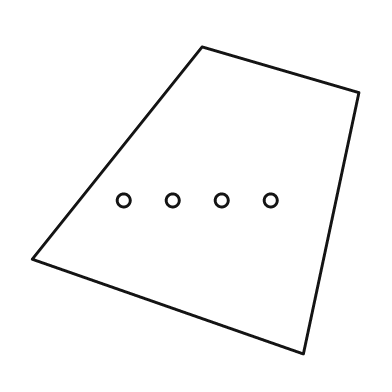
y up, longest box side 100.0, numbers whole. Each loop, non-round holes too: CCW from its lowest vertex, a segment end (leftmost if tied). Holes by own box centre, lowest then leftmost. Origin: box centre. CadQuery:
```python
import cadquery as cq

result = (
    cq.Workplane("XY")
    .moveTo(33.0, -47.0)
    .lineTo(50.0, 33.0)
    .lineTo(2.0, 47.0)
    .lineTo(-50.0, -18.0)
    .close()
    .moveTo(-22.0, 0.0)
    .circle(2.0)
    .moveTo(-7.0, 0.0)
    .circle(2.0)
    .moveTo(8.0, 0.0)
    .circle(2.0)
    .moveTo(23.0, 0.0)
    .circle(2.0)
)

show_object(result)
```